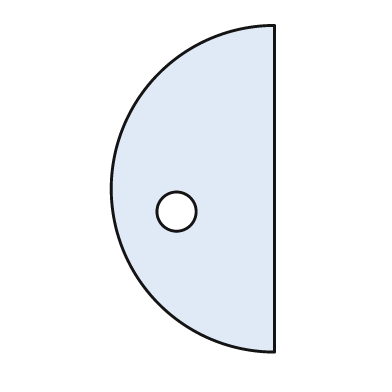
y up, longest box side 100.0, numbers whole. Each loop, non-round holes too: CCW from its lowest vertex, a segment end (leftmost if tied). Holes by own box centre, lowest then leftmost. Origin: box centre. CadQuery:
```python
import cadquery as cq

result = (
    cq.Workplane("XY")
    .moveTo(25.0, -50.0)
    .lineTo(25.0, 50.0)
    .threePointArc((-25.0, 0.0), (25.0, -50.0))
    .close()
    .moveTo(-5.0, -7.0)
    .circle(6.0)
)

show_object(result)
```